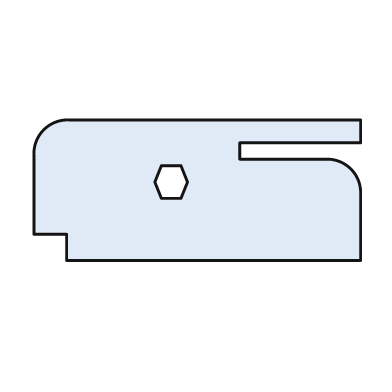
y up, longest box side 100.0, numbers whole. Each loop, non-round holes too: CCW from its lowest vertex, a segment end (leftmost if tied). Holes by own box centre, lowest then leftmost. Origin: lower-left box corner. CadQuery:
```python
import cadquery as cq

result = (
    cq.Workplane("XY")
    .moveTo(10.0, 0.0)
    .lineTo(100.0, 0.0)
    .lineTo(100.0, 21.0)
    .threePointArc((97.0, 28.0), (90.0, 31.0))
    .lineTo(63.0, 31.0)
    .lineTo(63.0, 36.0)
    .lineTo(100.0, 36.0)
    .lineTo(100.0, 43.0)
    .lineTo(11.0, 43.0)
    .threePointArc((3.0, 40.0), (0.0, 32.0))
    .lineTo(0.0, 8.0)
    .lineTo(10.0, 8.0)
    .close()
    .moveTo(39.0, 19.0)
    .lineTo(45.0, 19.0)
    .lineTo(47.0, 24.0)
    .lineTo(45.0, 29.0)
    .lineTo(39.0, 29.0)
    .lineTo(37.0, 24.0)
    .close()
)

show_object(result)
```